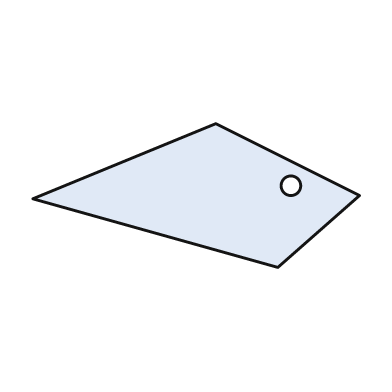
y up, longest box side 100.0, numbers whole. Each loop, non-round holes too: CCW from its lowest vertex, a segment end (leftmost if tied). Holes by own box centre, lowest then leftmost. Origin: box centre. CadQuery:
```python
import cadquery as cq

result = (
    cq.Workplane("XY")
    .moveTo(25.0, -22.0)
    .lineTo(50.0, 0.0)
    .lineTo(6.0, 22.0)
    .lineTo(-50.0, -1.0)
    .close()
    .moveTo(29.0, 3.0)
    .circle(3.0)
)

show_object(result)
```